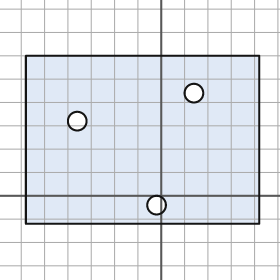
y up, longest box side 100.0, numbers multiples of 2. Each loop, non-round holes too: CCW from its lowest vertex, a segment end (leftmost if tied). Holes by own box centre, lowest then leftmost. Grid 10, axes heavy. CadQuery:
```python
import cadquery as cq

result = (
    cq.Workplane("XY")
    .moveTo(-58.0, -12.0)
    .lineTo(42.0, -12.0)
    .lineTo(42.0, 60.0)
    .lineTo(-58.0, 60.0)
    .close()
    .moveTo(-2.0, -4.0)
    .circle(4.0)
    .moveTo(-36.0, 32.0)
    .circle(4.0)
    .moveTo(14.0, 44.0)
    .circle(4.0)
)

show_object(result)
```